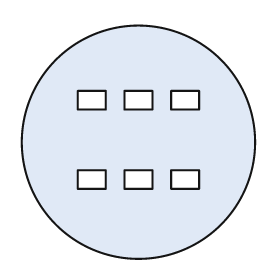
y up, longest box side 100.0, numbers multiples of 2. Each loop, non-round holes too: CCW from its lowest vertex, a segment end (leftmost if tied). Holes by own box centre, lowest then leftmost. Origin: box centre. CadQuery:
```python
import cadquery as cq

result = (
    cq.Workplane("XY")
    .moveTo(0.0, 0.0)
    .circle(50.0)
    .moveTo(-26.0, -20.0)
    .lineTo(-14.0, -20.0)
    .lineTo(-14.0, -12.0)
    .lineTo(-26.0, -12.0)
    .close()
    .moveTo(-6.0, -20.0)
    .lineTo(6.0, -20.0)
    .lineTo(6.0, -12.0)
    .lineTo(-6.0, -12.0)
    .close()
    .moveTo(14.0, -20.0)
    .lineTo(26.0, -20.0)
    .lineTo(26.0, -12.0)
    .lineTo(14.0, -12.0)
    .close()
    .moveTo(-26.0, 14.0)
    .lineTo(-14.0, 14.0)
    .lineTo(-14.0, 22.0)
    .lineTo(-26.0, 22.0)
    .close()
    .moveTo(-6.0, 14.0)
    .lineTo(6.0, 14.0)
    .lineTo(6.0, 22.0)
    .lineTo(-6.0, 22.0)
    .close()
    .moveTo(14.0, 14.0)
    .lineTo(26.0, 14.0)
    .lineTo(26.0, 22.0)
    .lineTo(14.0, 22.0)
    .close()
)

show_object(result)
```